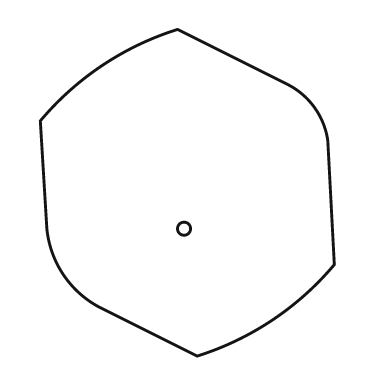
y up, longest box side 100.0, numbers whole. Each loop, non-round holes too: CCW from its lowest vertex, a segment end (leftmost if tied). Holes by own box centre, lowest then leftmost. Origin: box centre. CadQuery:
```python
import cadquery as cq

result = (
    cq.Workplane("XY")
    .moveTo(3.0, -50.0)
    .threePointArc((26.0, -39.0), (45.0, -22.0))
    .lineTo(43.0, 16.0)
    .threePointArc((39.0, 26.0), (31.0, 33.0))
    .lineTo(-3.0, 50.0)
    .threePointArc((-26.0, 39.0), (-45.0, 22.0))
    .lineTo(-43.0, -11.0)
    .threePointArc((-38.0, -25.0), (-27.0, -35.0))
    .close()
    .moveTo(-1.0, -11.0)
    .circle(2.0)
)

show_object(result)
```